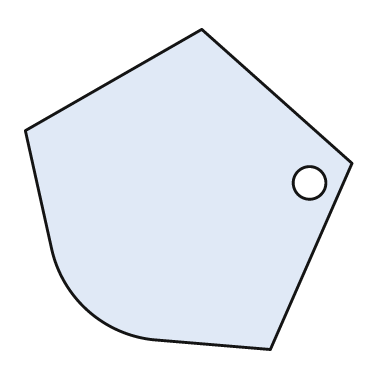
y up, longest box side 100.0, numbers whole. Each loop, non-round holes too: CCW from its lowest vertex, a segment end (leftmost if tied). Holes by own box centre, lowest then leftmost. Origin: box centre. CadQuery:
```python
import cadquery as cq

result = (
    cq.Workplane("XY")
    .moveTo(25.0, -49.0)
    .lineTo(50.0, 8.0)
    .lineTo(4.0, 49.0)
    .lineTo(-50.0, 18.0)
    .lineTo(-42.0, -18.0)
    .threePointArc((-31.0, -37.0), (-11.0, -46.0))
    .close()
    .moveTo(37.0, 2.0)
    .circle(5.0)
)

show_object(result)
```